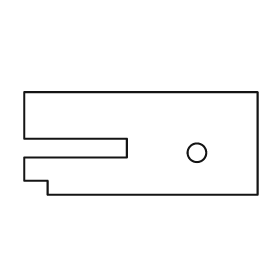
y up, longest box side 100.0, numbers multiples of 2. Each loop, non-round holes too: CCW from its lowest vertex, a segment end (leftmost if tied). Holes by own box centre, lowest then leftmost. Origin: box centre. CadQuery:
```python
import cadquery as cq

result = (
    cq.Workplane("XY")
    .moveTo(-40.0, -22.0)
    .lineTo(50.0, -22.0)
    .lineTo(50.0, 22.0)
    .lineTo(-50.0, 22.0)
    .lineTo(-50.0, 2.0)
    .lineTo(-6.0, 2.0)
    .lineTo(-6.0, -6.0)
    .lineTo(-50.0, -6.0)
    .lineTo(-50.0, -16.0)
    .lineTo(-40.0, -16.0)
    .close()
    .moveTo(24.0, -4.0)
    .circle(4.0)
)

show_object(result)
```